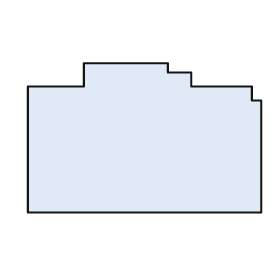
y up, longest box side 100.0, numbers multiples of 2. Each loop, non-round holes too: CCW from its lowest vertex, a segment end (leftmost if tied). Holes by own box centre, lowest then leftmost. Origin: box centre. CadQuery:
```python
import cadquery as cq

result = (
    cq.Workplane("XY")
    .moveTo(-50.0, -32.0)
    .lineTo(50.0, -32.0)
    .lineTo(50.0, 16.0)
    .lineTo(46.0, 16.0)
    .lineTo(46.0, 22.0)
    .lineTo(20.0, 22.0)
    .lineTo(20.0, 28.0)
    .lineTo(10.0, 28.0)
    .lineTo(10.0, 32.0)
    .lineTo(-26.0, 32.0)
    .lineTo(-26.0, 22.0)
    .lineTo(-50.0, 22.0)
    .close()
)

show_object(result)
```